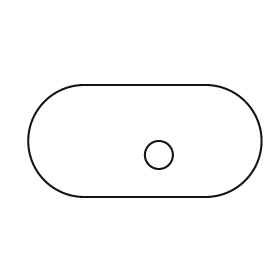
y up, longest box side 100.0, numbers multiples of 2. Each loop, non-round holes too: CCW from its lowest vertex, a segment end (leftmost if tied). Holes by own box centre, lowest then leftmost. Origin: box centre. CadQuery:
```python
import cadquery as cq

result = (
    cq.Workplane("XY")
    .moveTo(-26.0, -24.0)
    .lineTo(26.0, -24.0)
    .threePointArc((50.0, 0.0), (26.0, 24.0))
    .lineTo(-26.0, 24.0)
    .threePointArc((-50.0, 0.0), (-26.0, -24.0))
    .close()
    .moveTo(6.0, -6.0)
    .circle(6.0)
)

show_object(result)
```